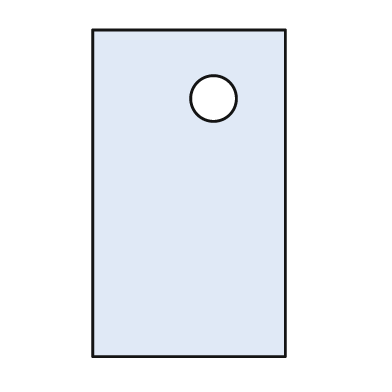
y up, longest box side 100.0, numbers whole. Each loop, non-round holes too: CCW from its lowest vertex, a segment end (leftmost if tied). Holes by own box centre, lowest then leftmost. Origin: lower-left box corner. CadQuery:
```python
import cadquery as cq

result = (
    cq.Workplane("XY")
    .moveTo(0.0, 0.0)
    .lineTo(59.0, 0.0)
    .lineTo(59.0, 100.0)
    .lineTo(0.0, 100.0)
    .close()
    .moveTo(37.0, 79.0)
    .circle(7.0)
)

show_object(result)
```